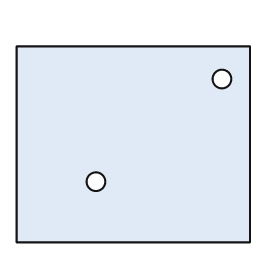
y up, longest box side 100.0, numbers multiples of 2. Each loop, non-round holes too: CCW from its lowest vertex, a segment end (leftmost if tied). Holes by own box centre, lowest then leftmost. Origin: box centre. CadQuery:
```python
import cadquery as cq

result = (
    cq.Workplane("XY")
    .moveTo(-50.0, -42.0)
    .lineTo(50.0, -42.0)
    .lineTo(50.0, 42.0)
    .lineTo(-50.0, 42.0)
    .close()
    .moveTo(-16.0, -16.0)
    .circle(4.0)
    .moveTo(38.0, 28.0)
    .circle(4.0)
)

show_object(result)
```